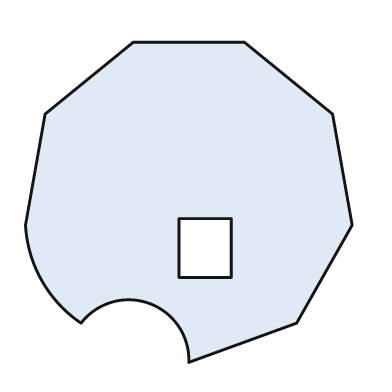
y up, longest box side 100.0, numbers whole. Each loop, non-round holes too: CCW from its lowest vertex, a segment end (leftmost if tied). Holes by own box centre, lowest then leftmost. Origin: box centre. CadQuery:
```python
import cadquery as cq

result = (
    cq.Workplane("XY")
    .moveTo(0.0, -49.0)
    .lineTo(33.0, -37.0)
    .lineTo(50.0, -7.0)
    .lineTo(44.0, 27.0)
    .lineTo(17.0, 49.0)
    .lineTo(-17.0, 49.0)
    .lineTo(-44.0, 27.0)
    .lineTo(-50.0, -7.0)
    .threePointArc((-45.0, -24.0), (-33.0, -37.0))
    .threePointArc((-12.0, -31.0), (0.0, -49.0))
    .close()
    .moveTo(-3.0, -23.0)
    .lineTo(13.0, -23.0)
    .lineTo(13.0, -5.0)
    .lineTo(-3.0, -5.0)
    .close()
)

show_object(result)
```